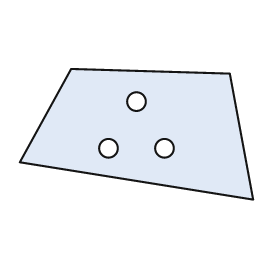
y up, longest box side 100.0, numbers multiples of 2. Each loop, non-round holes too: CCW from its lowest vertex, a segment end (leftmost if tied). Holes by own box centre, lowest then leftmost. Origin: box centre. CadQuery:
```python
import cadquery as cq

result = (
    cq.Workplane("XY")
    .moveTo(50.0, -28.0)
    .lineTo(40.0, 26.0)
    .lineTo(-28.0, 28.0)
    .lineTo(-50.0, -12.0)
    .close()
    .moveTo(-12.0, -6.0)
    .circle(4.0)
    .moveTo(12.0, -6.0)
    .circle(4.0)
    .moveTo(0.0, 14.0)
    .circle(4.0)
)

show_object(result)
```